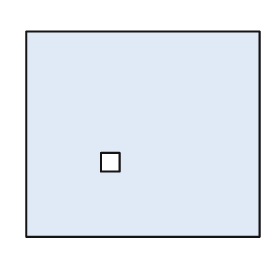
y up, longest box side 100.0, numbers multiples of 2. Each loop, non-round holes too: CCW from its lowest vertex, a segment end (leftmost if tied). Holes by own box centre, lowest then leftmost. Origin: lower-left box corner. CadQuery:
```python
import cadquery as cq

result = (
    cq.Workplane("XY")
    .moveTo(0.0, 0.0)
    .lineTo(100.0, 0.0)
    .lineTo(100.0, 88.0)
    .lineTo(0.0, 88.0)
    .close()
    .moveTo(32.0, 28.0)
    .lineTo(40.0, 28.0)
    .lineTo(40.0, 36.0)
    .lineTo(32.0, 36.0)
    .close()
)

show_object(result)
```